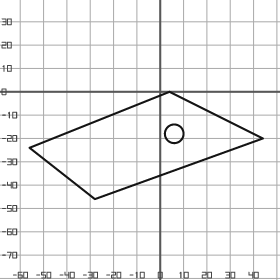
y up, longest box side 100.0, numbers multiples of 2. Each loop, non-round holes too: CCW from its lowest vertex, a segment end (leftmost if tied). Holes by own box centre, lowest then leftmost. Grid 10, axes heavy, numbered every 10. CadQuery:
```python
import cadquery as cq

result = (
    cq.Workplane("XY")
    .moveTo(-28.0, -46.0)
    .lineTo(44.0, -20.0)
    .lineTo(4.0, 0.0)
    .lineTo(-56.0, -24.0)
    .close()
    .moveTo(6.0, -18.0)
    .circle(4.0)
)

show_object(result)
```